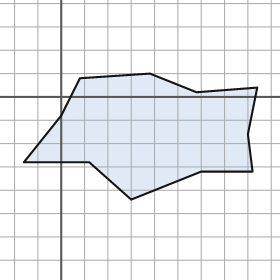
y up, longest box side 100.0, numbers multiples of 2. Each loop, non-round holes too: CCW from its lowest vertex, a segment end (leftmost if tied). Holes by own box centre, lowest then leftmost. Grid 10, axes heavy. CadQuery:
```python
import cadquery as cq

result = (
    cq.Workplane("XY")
    .moveTo(30.0, -44.0)
    .lineTo(60.0, -32.0)
    .lineTo(82.0, -32.0)
    .lineTo(80.0, -16.0)
    .lineTo(84.0, 4.0)
    .lineTo(58.0, 2.0)
    .lineTo(38.0, 10.0)
    .lineTo(8.0, 8.0)
    .lineTo(0.0, -8.0)
    .lineTo(-16.0, -28.0)
    .lineTo(12.0, -28.0)
    .close()
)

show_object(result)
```